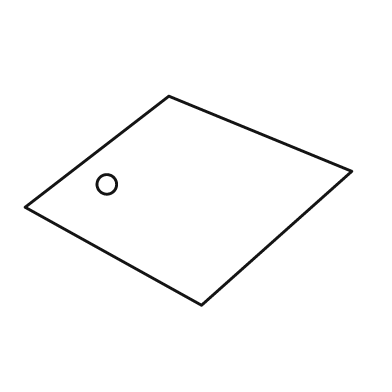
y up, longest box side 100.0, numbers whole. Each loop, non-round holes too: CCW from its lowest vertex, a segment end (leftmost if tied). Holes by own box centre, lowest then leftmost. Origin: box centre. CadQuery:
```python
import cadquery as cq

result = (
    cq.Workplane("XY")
    .moveTo(4.0, -32.0)
    .lineTo(50.0, 9.0)
    .lineTo(-6.0, 32.0)
    .lineTo(-50.0, -2.0)
    .close()
    .moveTo(-25.0, 5.0)
    .circle(3.0)
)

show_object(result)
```